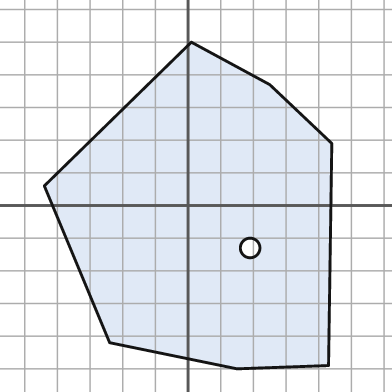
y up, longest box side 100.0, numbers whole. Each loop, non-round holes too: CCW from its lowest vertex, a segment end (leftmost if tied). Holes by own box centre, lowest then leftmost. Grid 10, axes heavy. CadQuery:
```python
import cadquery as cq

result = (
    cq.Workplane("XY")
    .moveTo(15.0, -50.0)
    .lineTo(43.0, -49.0)
    .lineTo(44.0, 19.0)
    .lineTo(25.0, 37.0)
    .lineTo(1.0, 50.0)
    .lineTo(-44.0, 6.0)
    .lineTo(-24.0, -42.0)
    .close()
    .moveTo(19.0, -13.0)
    .circle(3.0)
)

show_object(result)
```